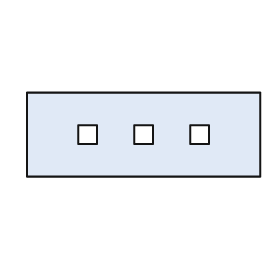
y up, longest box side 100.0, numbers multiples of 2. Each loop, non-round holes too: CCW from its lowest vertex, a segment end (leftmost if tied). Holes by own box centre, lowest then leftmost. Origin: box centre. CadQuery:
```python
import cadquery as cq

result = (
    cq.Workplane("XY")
    .moveTo(-50.0, -18.0)
    .lineTo(50.0, -18.0)
    .lineTo(50.0, 18.0)
    .lineTo(-50.0, 18.0)
    .close()
    .moveTo(-28.0, -4.0)
    .lineTo(-20.0, -4.0)
    .lineTo(-20.0, 4.0)
    .lineTo(-28.0, 4.0)
    .close()
    .moveTo(-4.0, -4.0)
    .lineTo(4.0, -4.0)
    .lineTo(4.0, 4.0)
    .lineTo(-4.0, 4.0)
    .close()
    .moveTo(20.0, -4.0)
    .lineTo(28.0, -4.0)
    .lineTo(28.0, 4.0)
    .lineTo(20.0, 4.0)
    .close()
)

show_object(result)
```